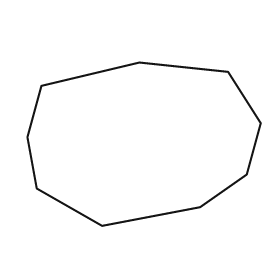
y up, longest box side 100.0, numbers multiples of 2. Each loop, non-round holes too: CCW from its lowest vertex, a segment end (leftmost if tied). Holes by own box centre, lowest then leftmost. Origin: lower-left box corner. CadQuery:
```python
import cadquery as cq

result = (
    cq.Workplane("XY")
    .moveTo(32.0, 0.0)
    .lineTo(74.0, 8.0)
    .lineTo(94.0, 22.0)
    .lineTo(100.0, 44.0)
    .lineTo(86.0, 66.0)
    .lineTo(48.0, 70.0)
    .lineTo(6.0, 60.0)
    .lineTo(0.0, 38.0)
    .lineTo(4.0, 16.0)
    .close()
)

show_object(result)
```